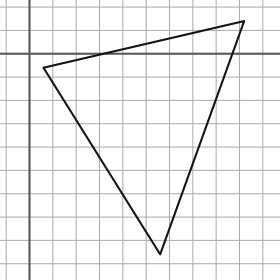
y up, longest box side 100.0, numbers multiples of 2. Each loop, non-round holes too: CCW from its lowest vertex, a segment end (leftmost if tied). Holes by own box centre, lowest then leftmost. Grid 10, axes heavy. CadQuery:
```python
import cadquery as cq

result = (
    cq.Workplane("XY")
    .moveTo(56.0, -86.0)
    .lineTo(92.0, 14.0)
    .lineTo(6.0, -6.0)
    .close()
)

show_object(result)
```